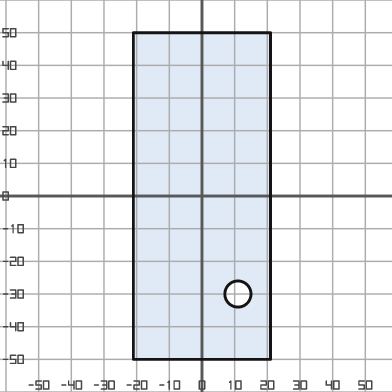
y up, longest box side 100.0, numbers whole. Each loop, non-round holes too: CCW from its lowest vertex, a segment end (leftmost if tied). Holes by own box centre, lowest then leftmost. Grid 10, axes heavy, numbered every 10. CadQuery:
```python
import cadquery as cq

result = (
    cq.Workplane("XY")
    .moveTo(-21.0, -50.0)
    .lineTo(21.0, -50.0)
    .lineTo(21.0, 50.0)
    .lineTo(-21.0, 50.0)
    .close()
    .moveTo(11.0, -30.0)
    .circle(4.0)
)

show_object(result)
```